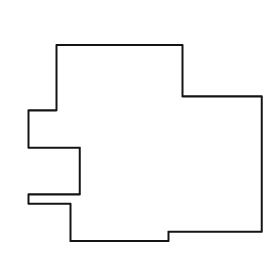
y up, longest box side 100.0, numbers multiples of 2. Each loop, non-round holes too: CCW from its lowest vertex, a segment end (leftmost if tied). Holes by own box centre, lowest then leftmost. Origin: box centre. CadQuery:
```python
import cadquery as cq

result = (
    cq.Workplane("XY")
    .moveTo(-32.0, -42.0)
    .lineTo(10.0, -42.0)
    .lineTo(10.0, -38.0)
    .lineTo(50.0, -38.0)
    .lineTo(50.0, 20.0)
    .lineTo(16.0, 20.0)
    .lineTo(16.0, 42.0)
    .lineTo(-38.0, 42.0)
    .lineTo(-38.0, 14.0)
    .lineTo(-50.0, 14.0)
    .lineTo(-50.0, -2.0)
    .lineTo(-28.0, -2.0)
    .lineTo(-28.0, -22.0)
    .lineTo(-50.0, -22.0)
    .lineTo(-50.0, -26.0)
    .lineTo(-32.0, -26.0)
    .close()
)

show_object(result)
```